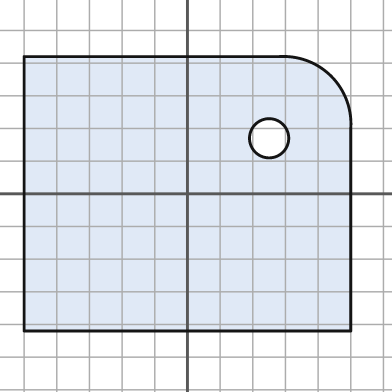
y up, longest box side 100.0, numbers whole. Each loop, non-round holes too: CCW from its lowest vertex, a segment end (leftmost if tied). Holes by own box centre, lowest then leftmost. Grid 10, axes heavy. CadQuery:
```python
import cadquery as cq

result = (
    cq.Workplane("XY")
    .moveTo(-50.0, -42.0)
    .lineTo(50.0, -42.0)
    .lineTo(50.0, 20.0)
    .threePointArc((44.0, 36.0), (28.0, 42.0))
    .lineTo(-50.0, 42.0)
    .close()
    .moveTo(25.0, 17.0)
    .circle(6.0)
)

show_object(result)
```